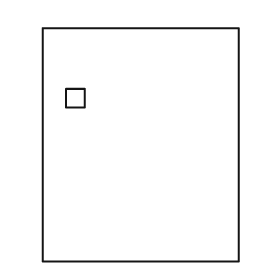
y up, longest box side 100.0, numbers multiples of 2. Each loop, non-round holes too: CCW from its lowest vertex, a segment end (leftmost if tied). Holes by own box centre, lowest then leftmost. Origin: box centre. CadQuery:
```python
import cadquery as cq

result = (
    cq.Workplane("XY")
    .moveTo(-42.0, -50.0)
    .lineTo(42.0, -50.0)
    .lineTo(42.0, 50.0)
    .lineTo(-42.0, 50.0)
    .close()
    .moveTo(-32.0, 16.0)
    .lineTo(-24.0, 16.0)
    .lineTo(-24.0, 24.0)
    .lineTo(-32.0, 24.0)
    .close()
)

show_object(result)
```